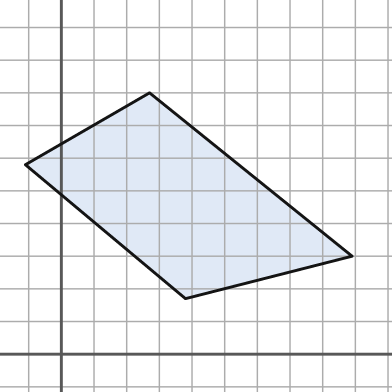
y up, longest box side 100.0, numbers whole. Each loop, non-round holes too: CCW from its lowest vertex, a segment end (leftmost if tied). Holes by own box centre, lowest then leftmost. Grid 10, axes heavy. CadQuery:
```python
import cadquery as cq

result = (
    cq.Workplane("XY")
    .moveTo(38.0, 17.0)
    .lineTo(89.0, 30.0)
    .lineTo(27.0, 80.0)
    .lineTo(-11.0, 58.0)
    .close()
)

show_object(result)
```